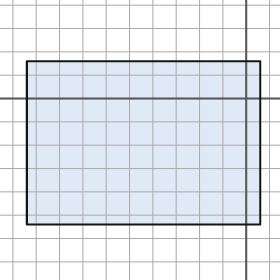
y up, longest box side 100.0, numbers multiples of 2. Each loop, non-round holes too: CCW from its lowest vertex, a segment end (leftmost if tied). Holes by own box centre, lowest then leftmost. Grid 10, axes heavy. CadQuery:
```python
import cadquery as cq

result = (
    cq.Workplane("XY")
    .moveTo(-94.0, -54.0)
    .lineTo(6.0, -54.0)
    .lineTo(6.0, 16.0)
    .lineTo(-94.0, 16.0)
    .close()
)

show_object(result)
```